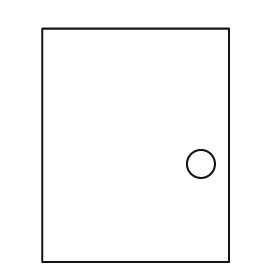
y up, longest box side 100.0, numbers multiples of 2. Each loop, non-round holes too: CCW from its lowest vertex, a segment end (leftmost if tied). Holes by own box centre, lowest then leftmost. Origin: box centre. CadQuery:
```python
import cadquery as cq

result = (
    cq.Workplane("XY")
    .moveTo(-40.0, -50.0)
    .lineTo(40.0, -50.0)
    .lineTo(40.0, 50.0)
    .lineTo(-40.0, 50.0)
    .close()
    .moveTo(28.0, -8.0)
    .circle(6.0)
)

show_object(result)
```